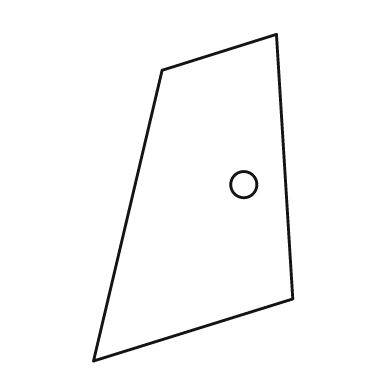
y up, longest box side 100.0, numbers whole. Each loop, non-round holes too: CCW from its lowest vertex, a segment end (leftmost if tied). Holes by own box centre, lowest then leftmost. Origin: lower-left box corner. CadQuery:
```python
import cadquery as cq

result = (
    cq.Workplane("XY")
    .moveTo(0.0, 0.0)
    .lineTo(61.0, 19.0)
    .lineTo(56.0, 100.0)
    .lineTo(21.0, 89.0)
    .close()
    .moveTo(46.0, 54.0)
    .circle(4.0)
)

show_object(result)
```